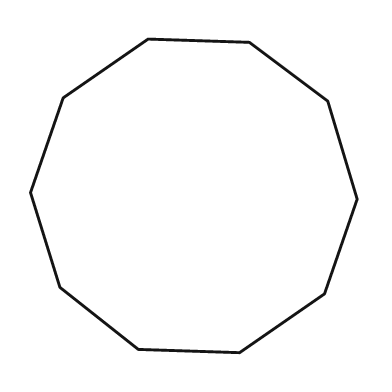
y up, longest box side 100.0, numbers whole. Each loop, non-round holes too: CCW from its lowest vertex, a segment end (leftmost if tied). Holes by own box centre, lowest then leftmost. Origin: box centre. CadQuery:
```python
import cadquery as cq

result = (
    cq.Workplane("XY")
    .moveTo(14.0, -48.0)
    .lineTo(40.0, -30.0)
    .lineTo(50.0, -1.0)
    .lineTo(41.0, 29.0)
    .lineTo(17.0, 47.0)
    .lineTo(-14.0, 48.0)
    .lineTo(-40.0, 30.0)
    .lineTo(-50.0, 1.0)
    .lineTo(-41.0, -28.0)
    .lineTo(-17.0, -47.0)
    .close()
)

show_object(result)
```